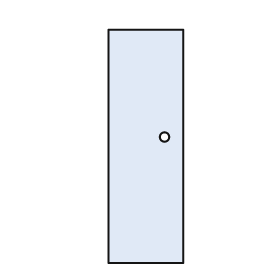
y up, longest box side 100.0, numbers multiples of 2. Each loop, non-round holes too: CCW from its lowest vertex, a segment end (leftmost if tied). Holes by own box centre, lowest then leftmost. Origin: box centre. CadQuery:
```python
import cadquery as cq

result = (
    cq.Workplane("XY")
    .moveTo(-16.0, -50.0)
    .lineTo(16.0, -50.0)
    .lineTo(16.0, 50.0)
    .lineTo(-16.0, 50.0)
    .close()
    .moveTo(8.0, 4.0)
    .circle(2.0)
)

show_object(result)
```